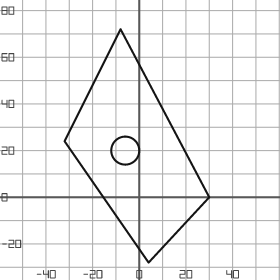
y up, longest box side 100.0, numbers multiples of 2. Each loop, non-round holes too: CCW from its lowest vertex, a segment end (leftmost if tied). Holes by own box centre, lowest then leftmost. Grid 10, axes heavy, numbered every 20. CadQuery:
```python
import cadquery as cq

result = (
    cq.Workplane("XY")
    .moveTo(4.0, -28.0)
    .lineTo(30.0, 0.0)
    .lineTo(-8.0, 72.0)
    .lineTo(-32.0, 24.0)
    .close()
    .moveTo(-6.0, 20.0)
    .circle(6.0)
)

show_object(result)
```